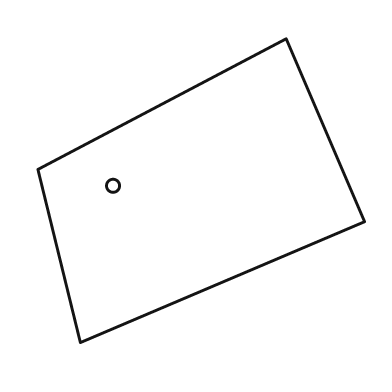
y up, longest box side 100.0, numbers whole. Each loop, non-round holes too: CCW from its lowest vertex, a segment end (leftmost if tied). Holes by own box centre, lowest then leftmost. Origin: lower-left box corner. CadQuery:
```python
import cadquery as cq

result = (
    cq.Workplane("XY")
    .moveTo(13.0, 0.0)
    .lineTo(100.0, 37.0)
    .lineTo(76.0, 93.0)
    .lineTo(0.0, 53.0)
    .close()
    .moveTo(23.0, 48.0)
    .circle(2.0)
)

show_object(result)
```